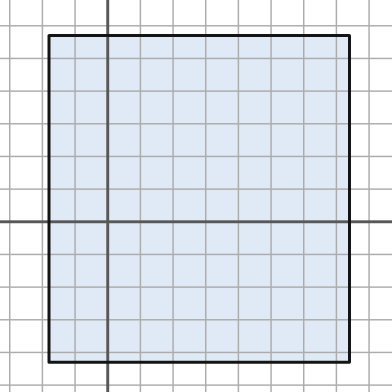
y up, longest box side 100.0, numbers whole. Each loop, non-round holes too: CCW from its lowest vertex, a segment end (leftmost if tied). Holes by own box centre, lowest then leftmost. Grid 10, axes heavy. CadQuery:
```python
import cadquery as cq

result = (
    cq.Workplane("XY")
    .moveTo(-18.0, -43.0)
    .lineTo(74.0, -43.0)
    .lineTo(74.0, 57.0)
    .lineTo(-18.0, 57.0)
    .close()
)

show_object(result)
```